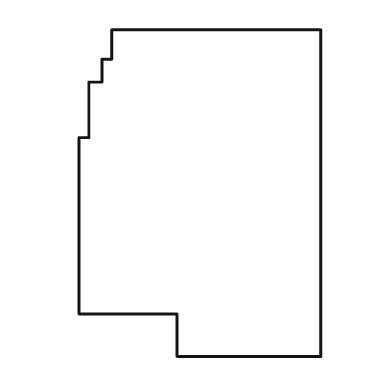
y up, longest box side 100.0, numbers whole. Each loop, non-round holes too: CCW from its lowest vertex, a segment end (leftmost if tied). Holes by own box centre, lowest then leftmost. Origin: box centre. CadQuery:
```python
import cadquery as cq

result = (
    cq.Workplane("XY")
    .moveTo(-7.0, -50.0)
    .lineTo(37.0, -50.0)
    .lineTo(37.0, 50.0)
    .lineTo(-27.0, 50.0)
    .lineTo(-27.0, 41.0)
    .lineTo(-30.0, 41.0)
    .lineTo(-30.0, 34.0)
    .lineTo(-34.0, 34.0)
    .lineTo(-34.0, 17.0)
    .lineTo(-37.0, 17.0)
    .lineTo(-37.0, -37.0)
    .lineTo(-7.0, -37.0)
    .close()
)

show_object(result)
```